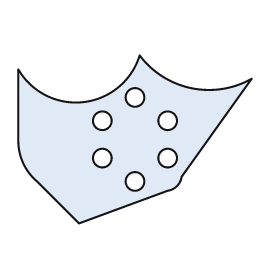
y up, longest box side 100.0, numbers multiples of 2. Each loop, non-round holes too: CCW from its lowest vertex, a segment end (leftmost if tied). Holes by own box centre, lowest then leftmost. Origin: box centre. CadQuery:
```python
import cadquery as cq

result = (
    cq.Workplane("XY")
    .moveTo(-24.0, -36.0)
    .lineTo(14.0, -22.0)
    .threePointArc((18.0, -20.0), (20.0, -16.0))
    .lineTo(50.0, 26.0)
    .threePointArc((24.0, 22.0), (2.0, 36.0))
    .threePointArc((-22.0, 16.0), (-50.0, 30.0))
    .lineTo(-50.0, 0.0)
    .threePointArc((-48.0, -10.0), (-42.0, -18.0))
    .close()
    .moveTo(0.0, -18.0)
    .circle(4.0)
    .moveTo(-14.0, -8.0)
    .circle(4.0)
    .moveTo(14.0, -8.0)
    .circle(4.0)
    .moveTo(-14.0, 8.0)
    .circle(4.0)
    .moveTo(14.0, 8.0)
    .circle(4.0)
    .moveTo(0.0, 18.0)
    .circle(4.0)
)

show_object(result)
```